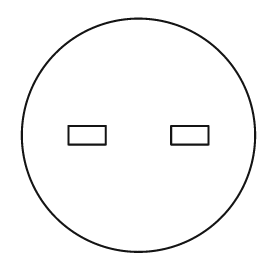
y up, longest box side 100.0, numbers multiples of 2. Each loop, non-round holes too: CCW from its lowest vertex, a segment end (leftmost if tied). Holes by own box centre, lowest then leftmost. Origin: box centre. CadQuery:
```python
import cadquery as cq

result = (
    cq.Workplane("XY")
    .moveTo(0.0, 0.0)
    .circle(50.0)
    .moveTo(-30.0, -4.0)
    .lineTo(-14.0, -4.0)
    .lineTo(-14.0, 4.0)
    .lineTo(-30.0, 4.0)
    .close()
    .moveTo(14.0, -4.0)
    .lineTo(30.0, -4.0)
    .lineTo(30.0, 4.0)
    .lineTo(14.0, 4.0)
    .close()
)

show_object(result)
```